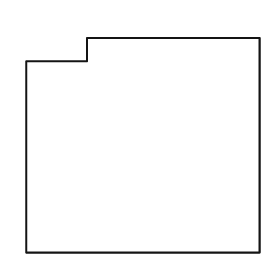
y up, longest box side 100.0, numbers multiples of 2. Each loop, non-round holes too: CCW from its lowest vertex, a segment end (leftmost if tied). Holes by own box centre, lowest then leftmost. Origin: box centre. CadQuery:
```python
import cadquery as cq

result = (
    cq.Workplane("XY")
    .moveTo(-50.0, -46.0)
    .lineTo(50.0, -46.0)
    .lineTo(50.0, 46.0)
    .lineTo(-24.0, 46.0)
    .lineTo(-24.0, 36.0)
    .lineTo(-50.0, 36.0)
    .close()
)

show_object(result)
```